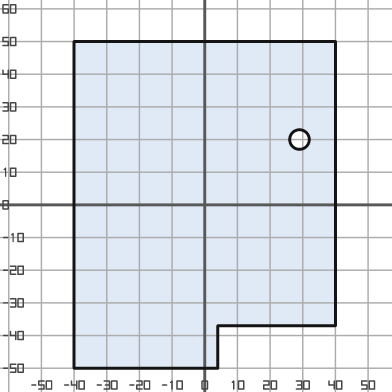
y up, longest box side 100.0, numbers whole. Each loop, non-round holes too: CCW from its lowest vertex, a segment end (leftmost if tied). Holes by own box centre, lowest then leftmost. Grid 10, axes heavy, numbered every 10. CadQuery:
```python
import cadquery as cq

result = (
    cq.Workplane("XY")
    .moveTo(-40.0, -50.0)
    .lineTo(4.0, -50.0)
    .lineTo(4.0, -37.0)
    .lineTo(40.0, -37.0)
    .lineTo(40.0, 50.0)
    .lineTo(-40.0, 50.0)
    .close()
    .moveTo(29.0, 20.0)
    .circle(3.0)
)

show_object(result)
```